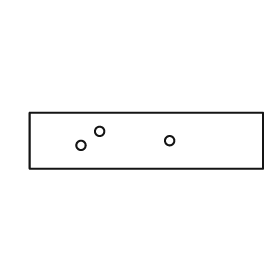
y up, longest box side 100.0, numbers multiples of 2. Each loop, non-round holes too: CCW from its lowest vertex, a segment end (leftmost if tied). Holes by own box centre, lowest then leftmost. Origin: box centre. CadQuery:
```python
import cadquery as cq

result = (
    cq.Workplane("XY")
    .moveTo(-50.0, -12.0)
    .lineTo(50.0, -12.0)
    .lineTo(50.0, 12.0)
    .lineTo(-50.0, 12.0)
    .close()
    .moveTo(-28.0, -2.0)
    .circle(2.0)
    .moveTo(10.0, 0.0)
    .circle(2.0)
    .moveTo(-20.0, 4.0)
    .circle(2.0)
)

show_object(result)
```